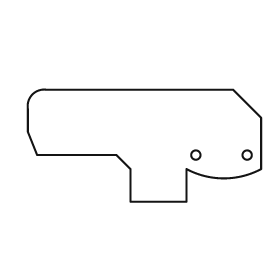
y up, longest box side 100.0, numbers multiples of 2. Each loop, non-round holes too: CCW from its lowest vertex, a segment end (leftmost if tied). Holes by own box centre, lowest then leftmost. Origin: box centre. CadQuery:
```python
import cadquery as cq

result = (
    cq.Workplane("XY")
    .moveTo(-6.0, -24.0)
    .lineTo(18.0, -24.0)
    .lineTo(18.0, -10.0)
    .threePointArc((34.0, -14.0), (50.0, -10.0))
    .lineTo(50.0, 12.0)
    .lineTo(38.0, 24.0)
    .lineTo(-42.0, 24.0)
    .threePointArc((-48.0, 22.0), (-50.0, 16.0))
    .lineTo(-50.0, 6.0)
    .lineTo(-46.0, -4.0)
    .lineTo(-12.0, -4.0)
    .lineTo(-6.0, -10.0)
    .close()
    .moveTo(22.0, -4.0)
    .circle(2.0)
    .moveTo(44.0, -4.0)
    .circle(2.0)
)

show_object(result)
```